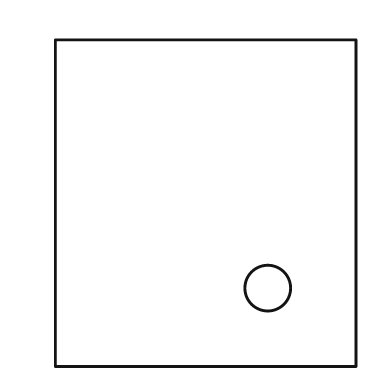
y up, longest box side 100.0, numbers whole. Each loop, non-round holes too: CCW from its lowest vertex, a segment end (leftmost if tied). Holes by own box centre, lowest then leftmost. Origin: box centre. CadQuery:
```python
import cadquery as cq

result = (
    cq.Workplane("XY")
    .moveTo(-46.0, -50.0)
    .lineTo(46.0, -50.0)
    .lineTo(46.0, 50.0)
    .lineTo(-46.0, 50.0)
    .close()
    .moveTo(19.0, -26.0)
    .circle(7.0)
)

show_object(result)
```